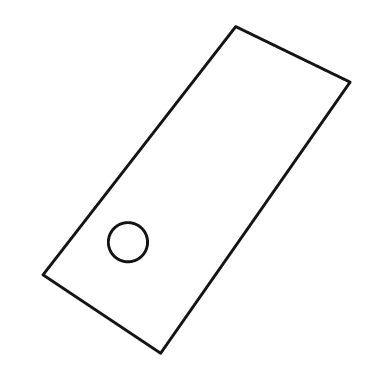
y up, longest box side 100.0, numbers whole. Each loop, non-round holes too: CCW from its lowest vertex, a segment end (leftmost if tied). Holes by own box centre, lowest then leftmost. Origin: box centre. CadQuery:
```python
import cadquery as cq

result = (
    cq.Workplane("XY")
    .moveTo(-11.0, -50.0)
    .lineTo(47.0, 33.0)
    .lineTo(12.0, 50.0)
    .lineTo(-47.0, -26.0)
    .close()
    .moveTo(-21.0, -16.0)
    .circle(6.0)
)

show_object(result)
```